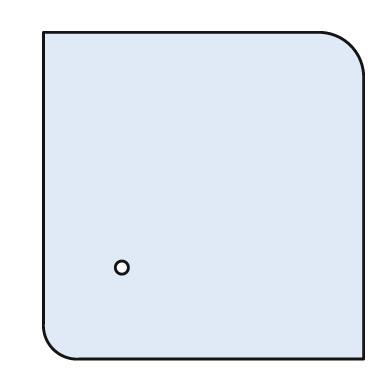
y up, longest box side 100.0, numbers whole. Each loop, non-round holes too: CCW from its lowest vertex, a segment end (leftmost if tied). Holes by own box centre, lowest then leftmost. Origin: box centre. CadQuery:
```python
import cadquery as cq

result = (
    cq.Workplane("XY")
    .moveTo(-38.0, -50.0)
    .lineTo(49.0, -50.0)
    .lineTo(49.0, 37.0)
    .threePointArc((45.0, 46.0), (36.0, 50.0))
    .lineTo(-49.0, 50.0)
    .lineTo(-49.0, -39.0)
    .threePointArc((-46.0, -47.0), (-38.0, -50.0))
    .close()
    .moveTo(-25.0, -22.0)
    .circle(2.0)
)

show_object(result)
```